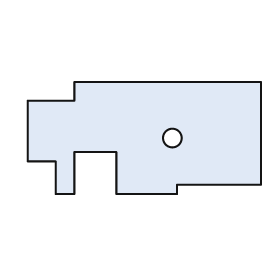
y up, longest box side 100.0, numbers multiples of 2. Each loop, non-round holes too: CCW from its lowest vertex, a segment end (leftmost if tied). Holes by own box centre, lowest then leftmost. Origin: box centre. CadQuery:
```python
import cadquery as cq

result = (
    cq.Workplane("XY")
    .moveTo(-38.0, -24.0)
    .lineTo(-30.0, -24.0)
    .lineTo(-30.0, -6.0)
    .lineTo(-12.0, -6.0)
    .lineTo(-12.0, -24.0)
    .lineTo(14.0, -24.0)
    .lineTo(14.0, -20.0)
    .lineTo(50.0, -20.0)
    .lineTo(50.0, 24.0)
    .lineTo(-30.0, 24.0)
    .lineTo(-30.0, 16.0)
    .lineTo(-50.0, 16.0)
    .lineTo(-50.0, -10.0)
    .lineTo(-38.0, -10.0)
    .close()
    .moveTo(12.0, 0.0)
    .circle(4.0)
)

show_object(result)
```